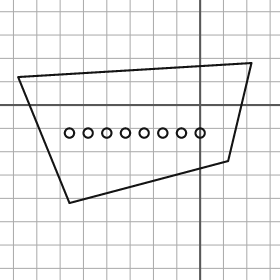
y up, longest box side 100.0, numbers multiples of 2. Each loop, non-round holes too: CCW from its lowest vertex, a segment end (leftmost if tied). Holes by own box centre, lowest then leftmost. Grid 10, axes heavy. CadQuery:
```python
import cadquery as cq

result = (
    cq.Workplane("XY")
    .moveTo(-56.0, -42.0)
    .lineTo(12.0, -24.0)
    .lineTo(22.0, 18.0)
    .lineTo(-78.0, 12.0)
    .close()
    .moveTo(-56.0, -12.0)
    .circle(2.0)
    .moveTo(-48.0, -12.0)
    .circle(2.0)
    .moveTo(-40.0, -12.0)
    .circle(2.0)
    .moveTo(-32.0, -12.0)
    .circle(2.0)
    .moveTo(-24.0, -12.0)
    .circle(2.0)
    .moveTo(-16.0, -12.0)
    .circle(2.0)
    .moveTo(-8.0, -12.0)
    .circle(2.0)
    .moveTo(0.0, -12.0)
    .circle(2.0)
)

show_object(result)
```